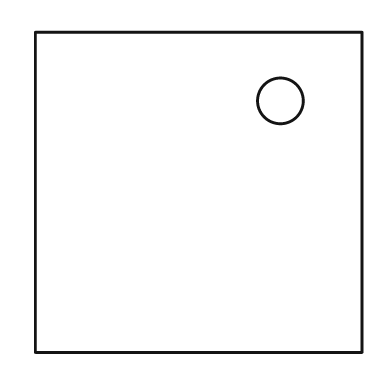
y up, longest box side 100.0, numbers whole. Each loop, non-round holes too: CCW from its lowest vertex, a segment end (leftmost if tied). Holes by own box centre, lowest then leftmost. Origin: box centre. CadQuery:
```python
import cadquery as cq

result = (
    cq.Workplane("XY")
    .moveTo(-50.0, -49.0)
    .lineTo(50.0, -49.0)
    .lineTo(50.0, 49.0)
    .lineTo(-50.0, 49.0)
    .close()
    .moveTo(25.0, 28.0)
    .circle(7.0)
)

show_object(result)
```